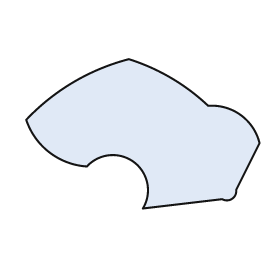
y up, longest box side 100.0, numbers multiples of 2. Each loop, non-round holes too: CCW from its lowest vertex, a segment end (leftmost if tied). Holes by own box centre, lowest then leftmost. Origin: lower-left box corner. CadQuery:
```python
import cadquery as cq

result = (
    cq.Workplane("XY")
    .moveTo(50.0, 0.0)
    .lineTo(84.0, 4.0)
    .threePointArc((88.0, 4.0), (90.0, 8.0))
    .lineTo(100.0, 28.0)
    .threePointArc((92.0, 40.0), (78.0, 44.0))
    .threePointArc((62.0, 56.0), (44.0, 64.0))
    .threePointArc((20.0, 54.0), (0.0, 38.0))
    .threePointArc((10.0, 24.0), (26.0, 18.0))
    .threePointArc((46.0, 20.0), (50.0, 0.0))
    .close()
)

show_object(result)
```